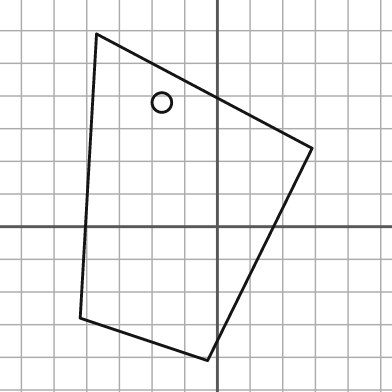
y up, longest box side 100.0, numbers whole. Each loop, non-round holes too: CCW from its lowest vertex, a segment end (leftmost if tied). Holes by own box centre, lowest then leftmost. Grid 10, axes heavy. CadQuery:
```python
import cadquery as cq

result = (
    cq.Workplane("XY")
    .moveTo(-3.0, -41.0)
    .lineTo(29.0, 24.0)
    .lineTo(-37.0, 59.0)
    .lineTo(-42.0, -28.0)
    .close()
    .moveTo(-17.0, 38.0)
    .circle(3.0)
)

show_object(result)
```